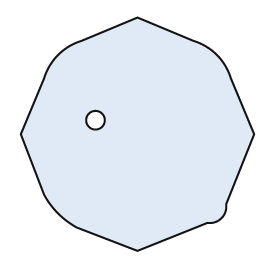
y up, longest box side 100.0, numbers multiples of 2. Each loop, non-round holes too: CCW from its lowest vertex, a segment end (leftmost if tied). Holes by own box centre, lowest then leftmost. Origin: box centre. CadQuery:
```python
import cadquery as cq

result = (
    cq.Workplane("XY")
    .moveTo(0.0, -50.0)
    .lineTo(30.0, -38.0)
    .threePointArc((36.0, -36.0), (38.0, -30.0))
    .lineTo(50.0, 0.0)
    .lineTo(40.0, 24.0)
    .threePointArc((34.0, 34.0), (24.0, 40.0))
    .lineTo(0.0, 50.0)
    .lineTo(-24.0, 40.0)
    .threePointArc((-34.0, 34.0), (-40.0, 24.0))
    .lineTo(-50.0, 0.0)
    .lineTo(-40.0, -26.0)
    .threePointArc((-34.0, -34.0), (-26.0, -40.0))
    .close()
    .moveTo(-18.0, 6.0)
    .circle(4.0)
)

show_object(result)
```